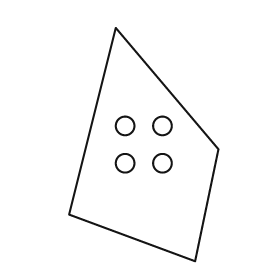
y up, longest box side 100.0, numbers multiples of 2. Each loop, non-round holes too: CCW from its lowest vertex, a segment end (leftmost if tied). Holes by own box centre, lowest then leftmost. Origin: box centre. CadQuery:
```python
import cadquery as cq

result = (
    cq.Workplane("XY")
    .moveTo(22.0, -50.0)
    .lineTo(32.0, -2.0)
    .lineTo(-12.0, 50.0)
    .lineTo(-32.0, -30.0)
    .close()
    .moveTo(-8.0, -8.0)
    .circle(4.0)
    .moveTo(8.0, -8.0)
    .circle(4.0)
    .moveTo(-8.0, 8.0)
    .circle(4.0)
    .moveTo(8.0, 8.0)
    .circle(4.0)
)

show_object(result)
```